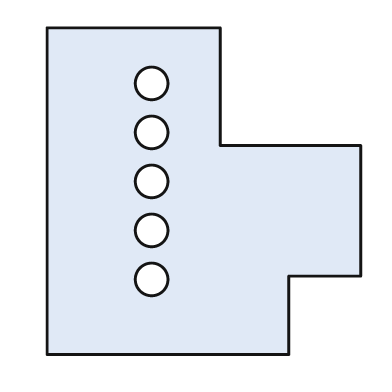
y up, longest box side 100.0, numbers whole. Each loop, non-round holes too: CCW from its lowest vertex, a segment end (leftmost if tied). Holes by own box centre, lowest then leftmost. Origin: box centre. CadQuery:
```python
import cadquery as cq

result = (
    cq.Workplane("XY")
    .moveTo(-48.0, -50.0)
    .lineTo(26.0, -50.0)
    .lineTo(26.0, -26.0)
    .lineTo(48.0, -26.0)
    .lineTo(48.0, 14.0)
    .lineTo(5.0, 14.0)
    .lineTo(5.0, 50.0)
    .lineTo(-48.0, 50.0)
    .close()
    .moveTo(-16.0, -27.0)
    .circle(5.0)
    .moveTo(-16.0, -12.0)
    .circle(5.0)
    .moveTo(-16.0, 3.0)
    .circle(5.0)
    .moveTo(-16.0, 18.0)
    .circle(5.0)
    .moveTo(-16.0, 33.0)
    .circle(5.0)
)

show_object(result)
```